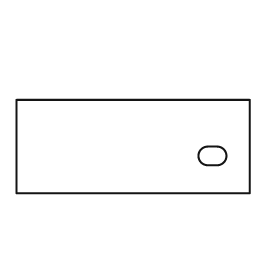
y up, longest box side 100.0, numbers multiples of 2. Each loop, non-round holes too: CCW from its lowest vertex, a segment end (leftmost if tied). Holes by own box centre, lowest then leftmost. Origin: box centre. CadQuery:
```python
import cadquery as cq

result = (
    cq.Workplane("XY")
    .moveTo(-50.0, -20.0)
    .lineTo(50.0, -20.0)
    .lineTo(50.0, 20.0)
    .lineTo(-50.0, 20.0)
    .close()
    .moveTo(32.0, -8.0)
    .lineTo(36.0, -8.0)
    .threePointArc((40.0, -4.0), (36.0, 0.0))
    .lineTo(32.0, 0.0)
    .threePointArc((28.0, -4.0), (32.0, -8.0))
    .close()
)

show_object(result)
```